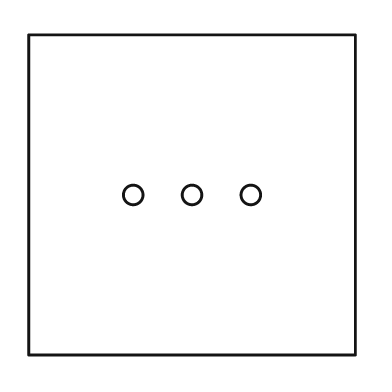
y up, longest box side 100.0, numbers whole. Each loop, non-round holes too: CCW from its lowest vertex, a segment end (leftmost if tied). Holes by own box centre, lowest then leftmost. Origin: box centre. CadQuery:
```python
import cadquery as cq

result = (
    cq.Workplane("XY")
    .moveTo(-50.0, -49.0)
    .lineTo(50.0, -49.0)
    .lineTo(50.0, 49.0)
    .lineTo(-50.0, 49.0)
    .close()
    .moveTo(-18.0, 0.0)
    .circle(3.0)
    .moveTo(0.0, 0.0)
    .circle(3.0)
    .moveTo(18.0, 0.0)
    .circle(3.0)
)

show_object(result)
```